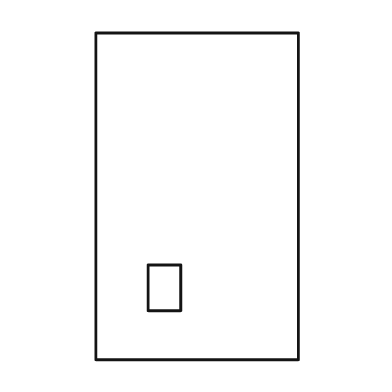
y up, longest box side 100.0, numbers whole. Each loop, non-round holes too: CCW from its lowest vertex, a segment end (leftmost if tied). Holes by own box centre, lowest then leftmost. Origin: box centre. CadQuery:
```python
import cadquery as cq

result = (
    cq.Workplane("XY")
    .moveTo(-31.0, -50.0)
    .lineTo(31.0, -50.0)
    .lineTo(31.0, 50.0)
    .lineTo(-31.0, 50.0)
    .close()
    .moveTo(-15.0, -35.0)
    .lineTo(-5.0, -35.0)
    .lineTo(-5.0, -21.0)
    .lineTo(-15.0, -21.0)
    .close()
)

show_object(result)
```